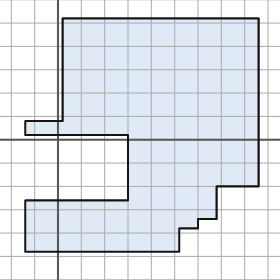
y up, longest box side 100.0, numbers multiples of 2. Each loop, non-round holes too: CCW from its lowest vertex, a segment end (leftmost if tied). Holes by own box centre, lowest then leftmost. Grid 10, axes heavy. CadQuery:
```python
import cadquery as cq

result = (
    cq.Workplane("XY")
    .moveTo(-14.0, -48.0)
    .lineTo(52.0, -48.0)
    .lineTo(52.0, -38.0)
    .lineTo(60.0, -38.0)
    .lineTo(60.0, -34.0)
    .lineTo(68.0, -34.0)
    .lineTo(68.0, -20.0)
    .lineTo(86.0, -20.0)
    .lineTo(86.0, 52.0)
    .lineTo(2.0, 52.0)
    .lineTo(2.0, 8.0)
    .lineTo(-14.0, 8.0)
    .lineTo(-14.0, 2.0)
    .lineTo(30.0, 2.0)
    .lineTo(30.0, -26.0)
    .lineTo(-14.0, -26.0)
    .close()
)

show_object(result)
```